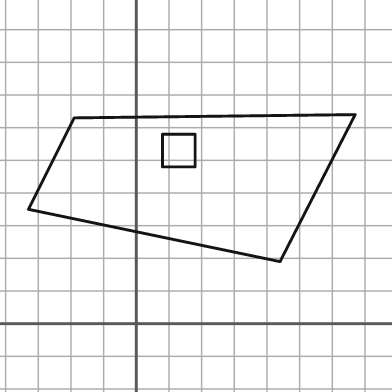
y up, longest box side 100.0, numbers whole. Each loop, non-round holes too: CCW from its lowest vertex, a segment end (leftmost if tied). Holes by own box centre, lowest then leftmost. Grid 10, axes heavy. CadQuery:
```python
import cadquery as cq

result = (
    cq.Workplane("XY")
    .moveTo(44.0, 19.0)
    .lineTo(67.0, 64.0)
    .lineTo(-19.0, 63.0)
    .lineTo(-33.0, 35.0)
    .close()
    .moveTo(8.0, 48.0)
    .lineTo(18.0, 48.0)
    .lineTo(18.0, 58.0)
    .lineTo(8.0, 58.0)
    .close()
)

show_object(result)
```